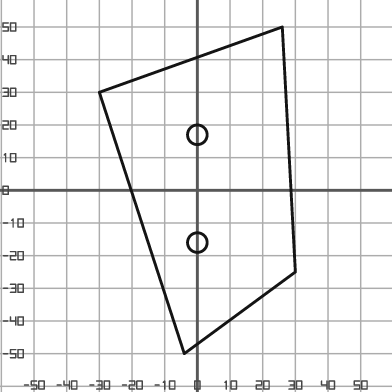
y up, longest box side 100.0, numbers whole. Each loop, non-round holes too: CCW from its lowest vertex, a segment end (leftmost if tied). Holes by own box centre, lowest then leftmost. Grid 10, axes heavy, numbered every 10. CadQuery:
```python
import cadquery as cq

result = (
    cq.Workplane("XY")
    .moveTo(-4.0, -50.0)
    .lineTo(30.0, -25.0)
    .lineTo(26.0, 50.0)
    .lineTo(-30.0, 30.0)
    .close()
    .moveTo(0.0, -16.0)
    .circle(3.0)
    .moveTo(0.0, 17.0)
    .circle(3.0)
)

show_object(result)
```